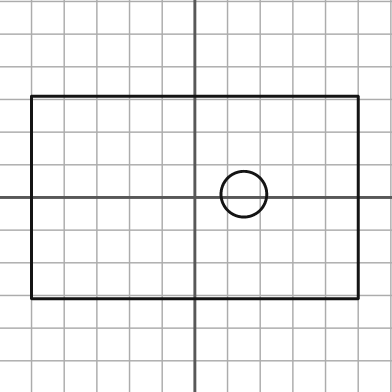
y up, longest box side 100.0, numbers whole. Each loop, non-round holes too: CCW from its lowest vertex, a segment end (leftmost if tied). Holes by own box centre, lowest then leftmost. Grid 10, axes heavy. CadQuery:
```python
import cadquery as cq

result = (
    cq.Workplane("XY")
    .moveTo(-50.0, -31.0)
    .lineTo(50.0, -31.0)
    .lineTo(50.0, 31.0)
    .lineTo(-50.0, 31.0)
    .close()
    .moveTo(15.0, 1.0)
    .circle(7.0)
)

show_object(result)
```